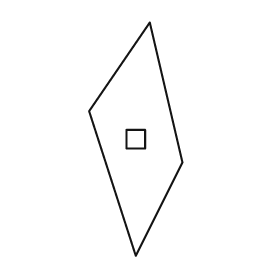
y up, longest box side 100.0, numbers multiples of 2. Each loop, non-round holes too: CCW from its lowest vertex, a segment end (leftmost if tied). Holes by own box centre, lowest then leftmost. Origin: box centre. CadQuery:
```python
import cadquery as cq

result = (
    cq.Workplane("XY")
    .moveTo(0.0, -50.0)
    .lineTo(20.0, -10.0)
    .lineTo(6.0, 50.0)
    .lineTo(-20.0, 12.0)
    .close()
    .moveTo(-4.0, -4.0)
    .lineTo(4.0, -4.0)
    .lineTo(4.0, 4.0)
    .lineTo(-4.0, 4.0)
    .close()
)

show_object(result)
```